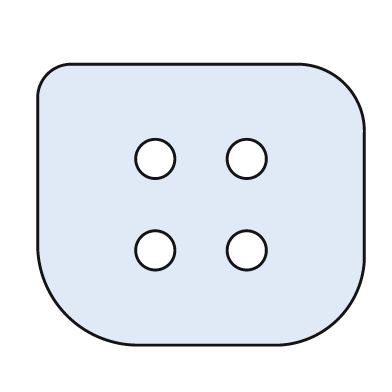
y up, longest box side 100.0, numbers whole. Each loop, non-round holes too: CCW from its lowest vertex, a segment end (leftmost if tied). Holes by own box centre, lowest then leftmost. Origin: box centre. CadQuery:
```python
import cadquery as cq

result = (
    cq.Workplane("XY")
    .moveTo(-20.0, -43.0)
    .lineTo(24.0, -43.0)
    .threePointArc((42.0, -35.0), (50.0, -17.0))
    .lineTo(50.0, 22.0)
    .threePointArc((44.0, 37.0), (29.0, 43.0))
    .lineTo(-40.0, 43.0)
    .threePointArc((-47.0, 40.0), (-50.0, 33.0))
    .lineTo(-50.0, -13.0)
    .threePointArc((-41.0, -34.0), (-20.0, -43.0))
    .close()
    .moveTo(-14.0, -14.0)
    .circle(6.0)
    .moveTo(14.0, -14.0)
    .circle(6.0)
    .moveTo(-14.0, 14.0)
    .circle(6.0)
    .moveTo(14.0, 14.0)
    .circle(6.0)
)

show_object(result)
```